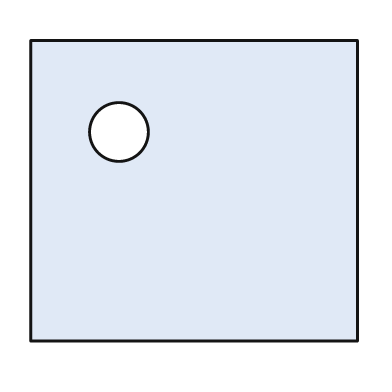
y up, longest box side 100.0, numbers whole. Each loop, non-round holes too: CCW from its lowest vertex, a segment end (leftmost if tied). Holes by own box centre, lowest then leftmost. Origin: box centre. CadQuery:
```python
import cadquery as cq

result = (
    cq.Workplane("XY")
    .moveTo(-50.0, -46.0)
    .lineTo(50.0, -46.0)
    .lineTo(50.0, 46.0)
    .lineTo(-50.0, 46.0)
    .close()
    .moveTo(-23.0, 18.0)
    .circle(9.0)
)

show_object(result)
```